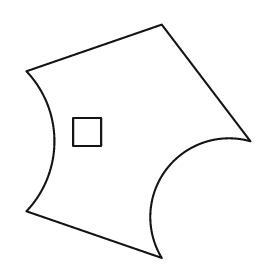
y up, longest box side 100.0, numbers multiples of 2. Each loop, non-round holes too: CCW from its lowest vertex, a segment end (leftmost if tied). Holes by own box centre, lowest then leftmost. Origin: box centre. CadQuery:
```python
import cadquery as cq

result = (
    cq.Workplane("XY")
    .moveTo(10.0, -50.0)
    .threePointArc((12.0, -12.0), (48.0, 0.0))
    .lineTo(10.0, 50.0)
    .lineTo(-48.0, 30.0)
    .threePointArc((-36.0, 0.0), (-48.0, -30.0))
    .close()
    .moveTo(-28.0, -2.0)
    .lineTo(-16.0, -2.0)
    .lineTo(-16.0, 10.0)
    .lineTo(-28.0, 10.0)
    .close()
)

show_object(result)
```